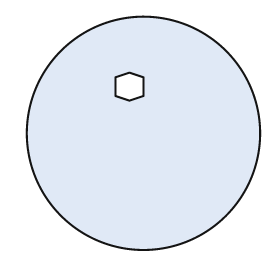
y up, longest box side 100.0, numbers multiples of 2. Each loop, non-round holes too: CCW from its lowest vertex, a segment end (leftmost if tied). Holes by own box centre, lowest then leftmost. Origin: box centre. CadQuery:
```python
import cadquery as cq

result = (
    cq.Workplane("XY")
    .moveTo(0.0, 0.0)
    .circle(50.0)
    .moveTo(-6.0, 14.0)
    .lineTo(0.0, 16.0)
    .lineTo(0.0, 24.0)
    .lineTo(-6.0, 26.0)
    .lineTo(-12.0, 24.0)
    .lineTo(-12.0, 16.0)
    .close()
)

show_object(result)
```